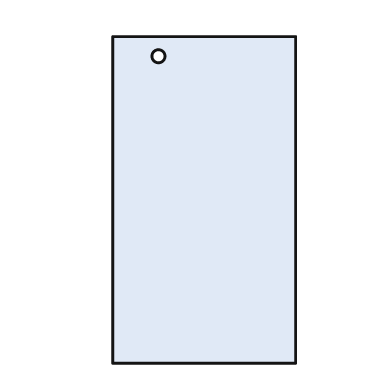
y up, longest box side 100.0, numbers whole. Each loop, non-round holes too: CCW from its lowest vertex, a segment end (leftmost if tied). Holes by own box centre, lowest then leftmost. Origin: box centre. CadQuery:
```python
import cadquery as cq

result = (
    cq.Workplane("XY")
    .moveTo(-28.0, -50.0)
    .lineTo(28.0, -50.0)
    .lineTo(28.0, 50.0)
    .lineTo(-28.0, 50.0)
    .close()
    .moveTo(-14.0, 44.0)
    .circle(2.0)
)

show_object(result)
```